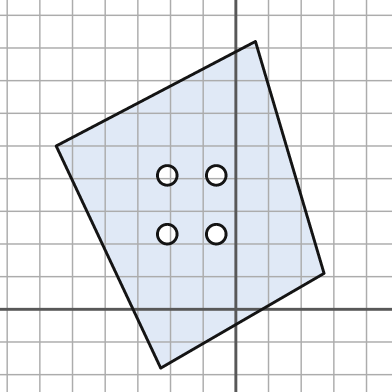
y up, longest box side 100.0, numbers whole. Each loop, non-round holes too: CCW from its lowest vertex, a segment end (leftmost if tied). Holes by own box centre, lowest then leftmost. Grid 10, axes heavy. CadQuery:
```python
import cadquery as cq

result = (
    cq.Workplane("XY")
    .moveTo(-23.0, -18.0)
    .lineTo(27.0, 11.0)
    .lineTo(6.0, 82.0)
    .lineTo(-55.0, 50.0)
    .close()
    .moveTo(-21.0, 23.0)
    .circle(3.0)
    .moveTo(-6.0, 23.0)
    .circle(3.0)
    .moveTo(-21.0, 41.0)
    .circle(3.0)
    .moveTo(-6.0, 41.0)
    .circle(3.0)
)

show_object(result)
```